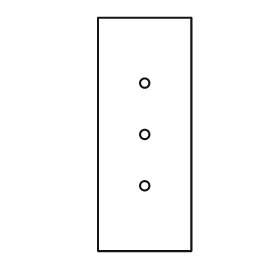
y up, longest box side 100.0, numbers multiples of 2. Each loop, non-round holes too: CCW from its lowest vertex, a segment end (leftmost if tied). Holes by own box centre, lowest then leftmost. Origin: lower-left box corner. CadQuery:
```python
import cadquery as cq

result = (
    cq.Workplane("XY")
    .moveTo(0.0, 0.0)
    .lineTo(40.0, 0.0)
    .lineTo(40.0, 100.0)
    .lineTo(0.0, 100.0)
    .close()
    .moveTo(20.0, 28.0)
    .circle(2.0)
    .moveTo(20.0, 50.0)
    .circle(2.0)
    .moveTo(20.0, 72.0)
    .circle(2.0)
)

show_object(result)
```